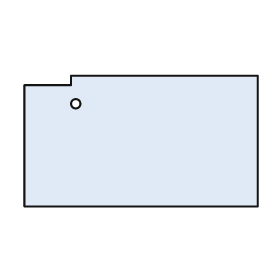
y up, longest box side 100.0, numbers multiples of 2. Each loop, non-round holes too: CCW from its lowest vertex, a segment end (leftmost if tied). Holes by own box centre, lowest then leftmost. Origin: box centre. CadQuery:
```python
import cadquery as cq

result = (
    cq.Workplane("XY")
    .moveTo(-50.0, -28.0)
    .lineTo(50.0, -28.0)
    .lineTo(50.0, 28.0)
    .lineTo(-30.0, 28.0)
    .lineTo(-30.0, 24.0)
    .lineTo(-50.0, 24.0)
    .close()
    .moveTo(-28.0, 16.0)
    .circle(2.0)
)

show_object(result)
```